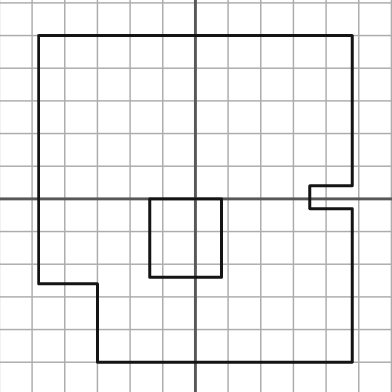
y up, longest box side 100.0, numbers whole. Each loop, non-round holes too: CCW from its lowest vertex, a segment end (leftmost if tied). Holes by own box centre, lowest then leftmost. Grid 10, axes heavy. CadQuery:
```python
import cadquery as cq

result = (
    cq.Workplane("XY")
    .moveTo(-30.0, -50.0)
    .lineTo(48.0, -50.0)
    .lineTo(48.0, -3.0)
    .lineTo(35.0, -3.0)
    .lineTo(35.0, 4.0)
    .lineTo(48.0, 4.0)
    .lineTo(48.0, 50.0)
    .lineTo(-48.0, 50.0)
    .lineTo(-48.0, -26.0)
    .lineTo(-30.0, -26.0)
    .close()
    .moveTo(-14.0, -24.0)
    .lineTo(8.0, -24.0)
    .lineTo(8.0, 0.0)
    .lineTo(-14.0, 0.0)
    .close()
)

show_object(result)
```